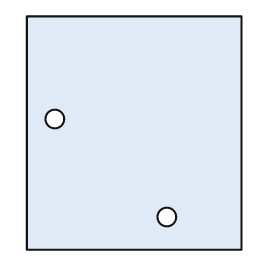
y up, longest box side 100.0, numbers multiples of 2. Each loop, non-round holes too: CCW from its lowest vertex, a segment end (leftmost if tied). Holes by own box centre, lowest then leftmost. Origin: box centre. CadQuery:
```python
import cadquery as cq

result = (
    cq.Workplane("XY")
    .moveTo(-46.0, -50.0)
    .lineTo(46.0, -50.0)
    .lineTo(46.0, 50.0)
    .lineTo(-46.0, 50.0)
    .close()
    .moveTo(14.0, -36.0)
    .circle(4.0)
    .moveTo(-34.0, 6.0)
    .circle(4.0)
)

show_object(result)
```